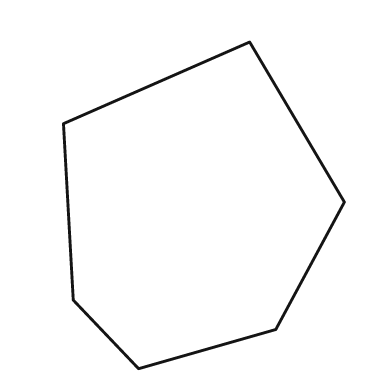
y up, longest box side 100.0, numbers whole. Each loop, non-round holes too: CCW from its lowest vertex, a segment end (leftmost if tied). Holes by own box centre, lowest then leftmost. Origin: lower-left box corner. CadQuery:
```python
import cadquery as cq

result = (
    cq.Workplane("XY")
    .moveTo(23.0, 0.0)
    .lineTo(65.0, 12.0)
    .lineTo(86.0, 51.0)
    .lineTo(57.0, 100.0)
    .lineTo(0.0, 75.0)
    .lineTo(3.0, 21.0)
    .close()
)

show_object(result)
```